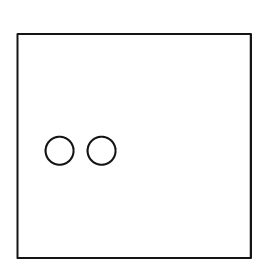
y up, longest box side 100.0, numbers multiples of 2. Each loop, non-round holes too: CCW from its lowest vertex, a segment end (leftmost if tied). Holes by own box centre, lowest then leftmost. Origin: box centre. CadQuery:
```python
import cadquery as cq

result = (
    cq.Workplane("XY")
    .moveTo(-50.0, -48.0)
    .lineTo(50.0, -48.0)
    .lineTo(50.0, 48.0)
    .lineTo(-50.0, 48.0)
    .close()
    .moveTo(-32.0, -2.0)
    .circle(6.0)
    .moveTo(-14.0, -2.0)
    .circle(6.0)
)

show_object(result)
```